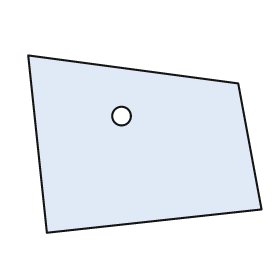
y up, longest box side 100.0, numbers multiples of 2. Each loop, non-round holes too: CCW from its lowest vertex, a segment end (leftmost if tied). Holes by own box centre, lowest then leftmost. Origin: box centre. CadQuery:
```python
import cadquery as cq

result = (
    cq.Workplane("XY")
    .moveTo(-42.0, -38.0)
    .lineTo(50.0, -28.0)
    .lineTo(40.0, 26.0)
    .lineTo(-50.0, 38.0)
    .close()
    .moveTo(-10.0, 12.0)
    .circle(4.0)
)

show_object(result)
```